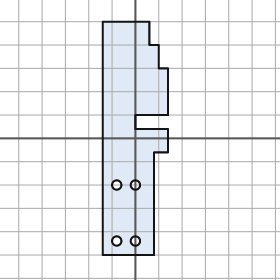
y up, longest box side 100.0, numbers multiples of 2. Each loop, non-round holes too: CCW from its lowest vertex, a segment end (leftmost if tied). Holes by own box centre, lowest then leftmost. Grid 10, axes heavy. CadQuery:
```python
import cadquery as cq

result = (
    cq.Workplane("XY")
    .moveTo(-14.0, -50.0)
    .lineTo(8.0, -50.0)
    .lineTo(8.0, -6.0)
    .lineTo(14.0, -6.0)
    .lineTo(14.0, 4.0)
    .lineTo(0.0, 4.0)
    .lineTo(0.0, 10.0)
    .lineTo(14.0, 10.0)
    .lineTo(14.0, 30.0)
    .lineTo(10.0, 30.0)
    .lineTo(10.0, 40.0)
    .lineTo(6.0, 40.0)
    .lineTo(6.0, 50.0)
    .lineTo(-14.0, 50.0)
    .close()
    .moveTo(-8.0, -44.0)
    .circle(2.0)
    .moveTo(0.0, -44.0)
    .circle(2.0)
    .moveTo(-8.0, -20.0)
    .circle(2.0)
    .moveTo(0.0, -20.0)
    .circle(2.0)
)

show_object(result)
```